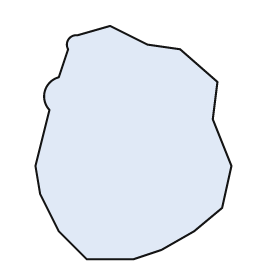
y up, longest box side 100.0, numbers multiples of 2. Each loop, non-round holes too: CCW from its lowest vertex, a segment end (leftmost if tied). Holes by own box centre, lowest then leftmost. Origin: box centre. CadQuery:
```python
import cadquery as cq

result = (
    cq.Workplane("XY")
    .moveTo(-20.0, -50.0)
    .lineTo(0.0, -50.0)
    .lineTo(12.0, -46.0)
    .lineTo(26.0, -38.0)
    .lineTo(38.0, -28.0)
    .lineTo(42.0, -10.0)
    .lineTo(34.0, 10.0)
    .lineTo(36.0, 26.0)
    .lineTo(20.0, 40.0)
    .lineTo(6.0, 42.0)
    .lineTo(-10.0, 50.0)
    .lineTo(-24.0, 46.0)
    .threePointArc((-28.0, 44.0), (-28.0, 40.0))
    .lineTo(-32.0, 28.0)
    .threePointArc((-38.0, 22.0), (-36.0, 14.0))
    .lineTo(-42.0, -10.0)
    .lineTo(-40.0, -22.0)
    .lineTo(-32.0, -38.0)
    .close()
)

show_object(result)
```